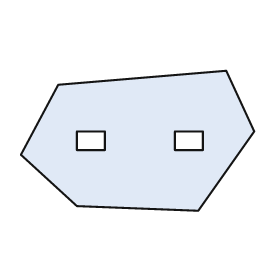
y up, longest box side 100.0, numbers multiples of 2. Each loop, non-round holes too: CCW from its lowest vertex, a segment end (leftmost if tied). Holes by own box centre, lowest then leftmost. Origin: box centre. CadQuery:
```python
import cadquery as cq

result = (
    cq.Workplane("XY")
    .moveTo(26.0, -30.0)
    .lineTo(50.0, 4.0)
    .lineTo(38.0, 30.0)
    .lineTo(-34.0, 24.0)
    .lineTo(-50.0, -6.0)
    .lineTo(-26.0, -28.0)
    .close()
    .moveTo(-26.0, -4.0)
    .lineTo(-14.0, -4.0)
    .lineTo(-14.0, 4.0)
    .lineTo(-26.0, 4.0)
    .close()
    .moveTo(16.0, -4.0)
    .lineTo(28.0, -4.0)
    .lineTo(28.0, 4.0)
    .lineTo(16.0, 4.0)
    .close()
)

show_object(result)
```